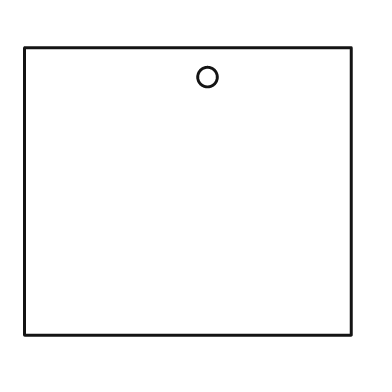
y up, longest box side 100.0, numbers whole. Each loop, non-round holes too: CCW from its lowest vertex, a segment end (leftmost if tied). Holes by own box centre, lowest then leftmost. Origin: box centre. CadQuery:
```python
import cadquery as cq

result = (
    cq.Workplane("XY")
    .moveTo(-50.0, -44.0)
    .lineTo(50.0, -44.0)
    .lineTo(50.0, 44.0)
    .lineTo(-50.0, 44.0)
    .close()
    .moveTo(6.0, 35.0)
    .circle(3.0)
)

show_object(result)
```